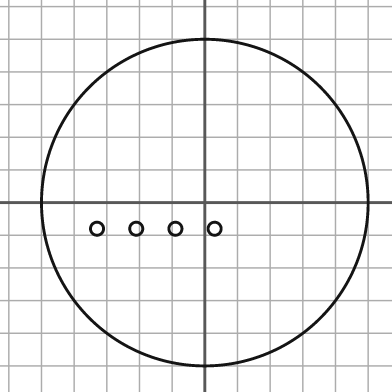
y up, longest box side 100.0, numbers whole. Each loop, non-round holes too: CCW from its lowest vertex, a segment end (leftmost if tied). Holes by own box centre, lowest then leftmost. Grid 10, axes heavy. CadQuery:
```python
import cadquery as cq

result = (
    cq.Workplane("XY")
    .moveTo(0.0, 0.0)
    .circle(50.0)
    .moveTo(-33.0, -8.0)
    .circle(2.0)
    .moveTo(-21.0, -8.0)
    .circle(2.0)
    .moveTo(-9.0, -8.0)
    .circle(2.0)
    .moveTo(3.0, -8.0)
    .circle(2.0)
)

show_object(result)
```